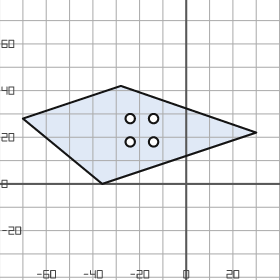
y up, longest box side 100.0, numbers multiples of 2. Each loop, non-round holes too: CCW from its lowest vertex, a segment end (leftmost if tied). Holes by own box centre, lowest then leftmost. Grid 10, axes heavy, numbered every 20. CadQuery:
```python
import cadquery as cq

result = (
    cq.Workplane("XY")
    .moveTo(-36.0, 0.0)
    .lineTo(30.0, 22.0)
    .lineTo(-28.0, 42.0)
    .lineTo(-70.0, 28.0)
    .close()
    .moveTo(-24.0, 18.0)
    .circle(2.0)
    .moveTo(-14.0, 18.0)
    .circle(2.0)
    .moveTo(-24.0, 28.0)
    .circle(2.0)
    .moveTo(-14.0, 28.0)
    .circle(2.0)
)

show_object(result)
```